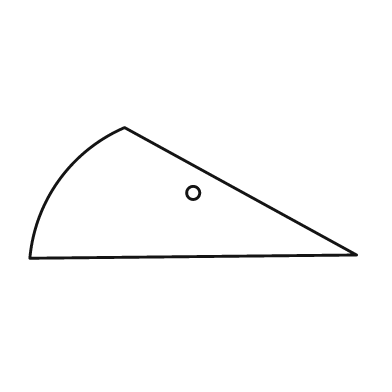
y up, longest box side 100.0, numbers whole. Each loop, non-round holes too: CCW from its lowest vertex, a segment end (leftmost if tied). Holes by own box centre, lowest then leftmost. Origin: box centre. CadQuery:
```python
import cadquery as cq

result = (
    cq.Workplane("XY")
    .moveTo(-50.0, -20.0)
    .lineTo(50.0, -19.0)
    .lineTo(-21.0, 20.0)
    .threePointArc((-41.0, 4.0), (-50.0, -20.0))
    .close()
    .moveTo(0.0, 0.0)
    .circle(2.0)
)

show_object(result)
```